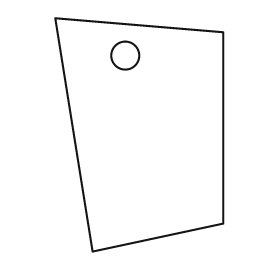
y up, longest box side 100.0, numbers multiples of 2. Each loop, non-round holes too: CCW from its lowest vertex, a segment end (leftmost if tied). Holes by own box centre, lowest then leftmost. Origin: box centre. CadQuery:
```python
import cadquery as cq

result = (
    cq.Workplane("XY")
    .moveTo(-20.0, -50.0)
    .lineTo(36.0, -38.0)
    .lineTo(36.0, 44.0)
    .lineTo(-36.0, 50.0)
    .close()
    .moveTo(-6.0, 34.0)
    .circle(6.0)
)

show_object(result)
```